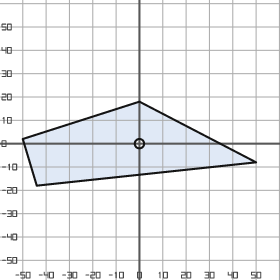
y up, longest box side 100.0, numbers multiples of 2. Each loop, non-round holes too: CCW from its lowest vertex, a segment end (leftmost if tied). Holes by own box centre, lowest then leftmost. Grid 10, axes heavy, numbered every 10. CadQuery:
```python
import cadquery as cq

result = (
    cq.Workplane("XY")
    .moveTo(-44.0, -18.0)
    .lineTo(50.0, -8.0)
    .lineTo(0.0, 18.0)
    .lineTo(-50.0, 2.0)
    .close()
    .moveTo(0.0, 0.0)
    .circle(2.0)
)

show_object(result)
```